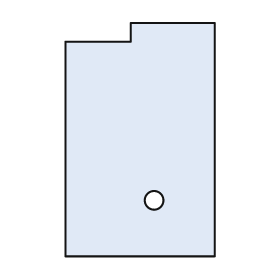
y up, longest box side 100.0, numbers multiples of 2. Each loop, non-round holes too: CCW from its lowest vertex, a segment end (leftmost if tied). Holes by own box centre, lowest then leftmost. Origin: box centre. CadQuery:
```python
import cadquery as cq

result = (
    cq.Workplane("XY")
    .moveTo(-32.0, -50.0)
    .lineTo(32.0, -50.0)
    .lineTo(32.0, 50.0)
    .lineTo(-4.0, 50.0)
    .lineTo(-4.0, 42.0)
    .lineTo(-32.0, 42.0)
    .close()
    .moveTo(6.0, -26.0)
    .circle(4.0)
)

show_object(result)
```